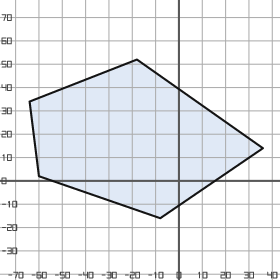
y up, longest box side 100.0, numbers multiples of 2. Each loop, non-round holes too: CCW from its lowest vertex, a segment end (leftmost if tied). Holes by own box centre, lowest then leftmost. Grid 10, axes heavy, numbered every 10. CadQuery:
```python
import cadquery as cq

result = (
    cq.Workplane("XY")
    .moveTo(-8.0, -16.0)
    .lineTo(36.0, 14.0)
    .lineTo(-18.0, 52.0)
    .lineTo(-64.0, 34.0)
    .lineTo(-60.0, 2.0)
    .close()
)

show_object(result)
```